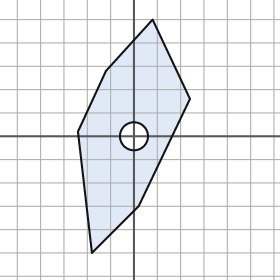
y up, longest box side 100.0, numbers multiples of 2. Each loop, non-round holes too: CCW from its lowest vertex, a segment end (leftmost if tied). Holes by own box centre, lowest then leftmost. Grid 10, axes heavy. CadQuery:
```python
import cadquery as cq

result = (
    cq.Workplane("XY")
    .moveTo(-18.0, -50.0)
    .lineTo(2.0, -30.0)
    .lineTo(24.0, 16.0)
    .lineTo(8.0, 50.0)
    .lineTo(-12.0, 28.0)
    .lineTo(-24.0, 2.0)
    .close()
    .moveTo(0.0, 0.0)
    .circle(6.0)
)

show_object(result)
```